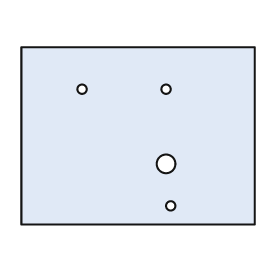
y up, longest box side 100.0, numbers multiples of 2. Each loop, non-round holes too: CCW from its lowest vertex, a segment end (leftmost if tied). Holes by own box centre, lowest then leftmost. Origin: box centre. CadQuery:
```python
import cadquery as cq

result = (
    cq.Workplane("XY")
    .moveTo(-50.0, -38.0)
    .lineTo(50.0, -38.0)
    .lineTo(50.0, 38.0)
    .lineTo(-50.0, 38.0)
    .close()
    .moveTo(14.0, -30.0)
    .circle(2.0)
    .moveTo(12.0, -12.0)
    .circle(4.0)
    .moveTo(-24.0, 20.0)
    .circle(2.0)
    .moveTo(12.0, 20.0)
    .circle(2.0)
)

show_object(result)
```